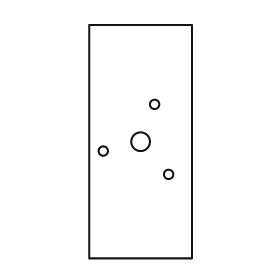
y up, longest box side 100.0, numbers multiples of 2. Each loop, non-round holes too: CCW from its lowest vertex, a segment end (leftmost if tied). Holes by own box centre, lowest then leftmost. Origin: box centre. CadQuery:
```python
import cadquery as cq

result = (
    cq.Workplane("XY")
    .moveTo(-22.0, -50.0)
    .lineTo(22.0, -50.0)
    .lineTo(22.0, 50.0)
    .lineTo(-22.0, 50.0)
    .close()
    .moveTo(12.0, -14.0)
    .circle(2.0)
    .moveTo(-16.0, -4.0)
    .circle(2.0)
    .moveTo(0.0, 0.0)
    .circle(4.0)
    .moveTo(6.0, 16.0)
    .circle(2.0)
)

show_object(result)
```